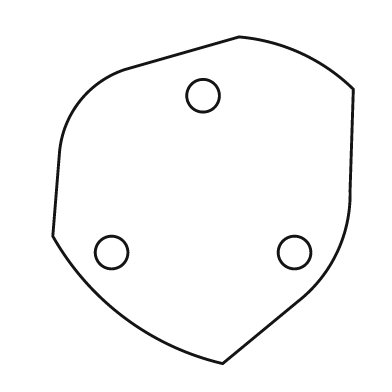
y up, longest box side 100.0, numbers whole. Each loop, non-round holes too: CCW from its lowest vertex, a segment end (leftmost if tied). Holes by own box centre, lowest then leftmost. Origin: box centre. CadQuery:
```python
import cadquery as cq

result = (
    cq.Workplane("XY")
    .moveTo(6.0, -50.0)
    .lineTo(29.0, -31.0)
    .threePointArc((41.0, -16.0), (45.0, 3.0))
    .lineTo(46.0, 34.0)
    .threePointArc((30.0, 45.0), (11.0, 50.0))
    .lineTo(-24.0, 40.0)
    .threePointArc((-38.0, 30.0), (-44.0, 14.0))
    .lineTo(-46.0, -11.0)
    .threePointArc((-24.0, -36.0), (6.0, -50.0))
    .close()
    .moveTo(-28.0, -16.0)
    .circle(5.0)
    .moveTo(28.0, -16.0)
    .circle(5.0)
    .moveTo(0.0, 32.0)
    .circle(5.0)
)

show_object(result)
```